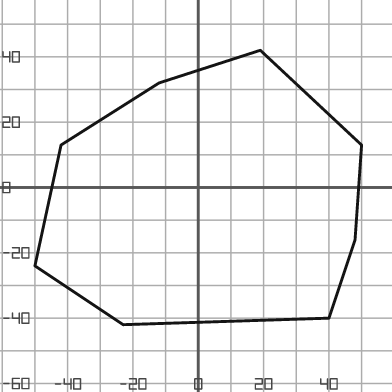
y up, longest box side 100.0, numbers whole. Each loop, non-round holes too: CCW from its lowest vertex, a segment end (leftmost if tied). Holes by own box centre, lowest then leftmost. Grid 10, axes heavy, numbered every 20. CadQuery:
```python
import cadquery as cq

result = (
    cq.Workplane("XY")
    .moveTo(-23.0, -42.0)
    .lineTo(40.0, -40.0)
    .lineTo(48.0, -16.0)
    .lineTo(50.0, 13.0)
    .lineTo(19.0, 42.0)
    .lineTo(-12.0, 32.0)
    .lineTo(-42.0, 13.0)
    .lineTo(-50.0, -24.0)
    .close()
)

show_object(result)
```